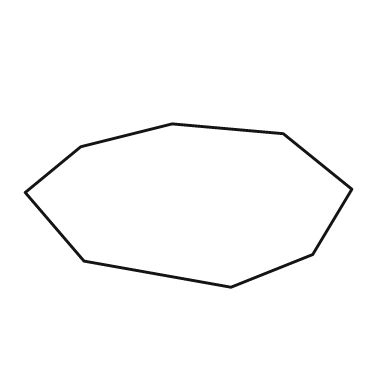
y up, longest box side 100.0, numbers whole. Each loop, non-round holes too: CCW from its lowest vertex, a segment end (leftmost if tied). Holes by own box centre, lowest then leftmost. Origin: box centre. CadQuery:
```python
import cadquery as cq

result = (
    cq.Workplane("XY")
    .moveTo(13.0, -25.0)
    .lineTo(38.0, -15.0)
    .lineTo(50.0, 5.0)
    .lineTo(29.0, 22.0)
    .lineTo(-5.0, 25.0)
    .lineTo(-33.0, 18.0)
    .lineTo(-50.0, 4.0)
    .lineTo(-32.0, -17.0)
    .close()
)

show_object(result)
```